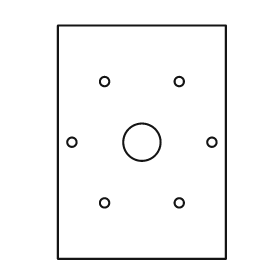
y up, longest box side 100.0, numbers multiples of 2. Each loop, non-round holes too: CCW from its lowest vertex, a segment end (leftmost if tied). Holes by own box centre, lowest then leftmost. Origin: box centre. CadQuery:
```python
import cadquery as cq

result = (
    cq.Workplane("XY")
    .moveTo(-36.0, -50.0)
    .lineTo(36.0, -50.0)
    .lineTo(36.0, 50.0)
    .lineTo(-36.0, 50.0)
    .close()
    .moveTo(-16.0, -26.0)
    .circle(2.0)
    .moveTo(16.0, -26.0)
    .circle(2.0)
    .moveTo(-30.0, 0.0)
    .circle(2.0)
    .moveTo(0.0, 0.0)
    .circle(8.0)
    .moveTo(30.0, 0.0)
    .circle(2.0)
    .moveTo(-16.0, 26.0)
    .circle(2.0)
    .moveTo(16.0, 26.0)
    .circle(2.0)
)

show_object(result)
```